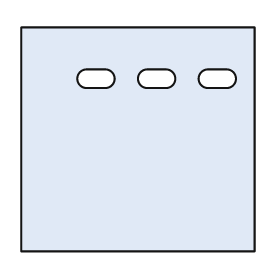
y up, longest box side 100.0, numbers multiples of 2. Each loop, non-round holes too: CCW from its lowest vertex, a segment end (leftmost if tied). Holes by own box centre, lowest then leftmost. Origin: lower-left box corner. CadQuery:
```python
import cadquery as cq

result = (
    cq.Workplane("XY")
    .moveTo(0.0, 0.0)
    .lineTo(100.0, 0.0)
    .lineTo(100.0, 96.0)
    .lineTo(0.0, 96.0)
    .close()
    .moveTo(28.0, 70.0)
    .lineTo(36.0, 70.0)
    .threePointArc((40.0, 74.0), (36.0, 78.0))
    .lineTo(28.0, 78.0)
    .threePointArc((24.0, 74.0), (28.0, 70.0))
    .close()
    .moveTo(54.0, 70.0)
    .lineTo(62.0, 70.0)
    .threePointArc((66.0, 74.0), (62.0, 78.0))
    .lineTo(54.0, 78.0)
    .threePointArc((50.0, 74.0), (54.0, 70.0))
    .close()
    .moveTo(80.0, 70.0)
    .lineTo(88.0, 70.0)
    .threePointArc((92.0, 74.0), (88.0, 78.0))
    .lineTo(80.0, 78.0)
    .threePointArc((76.0, 74.0), (80.0, 70.0))
    .close()
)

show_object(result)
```